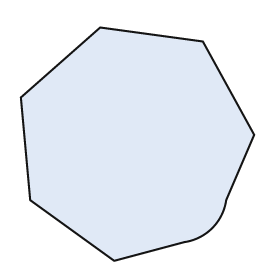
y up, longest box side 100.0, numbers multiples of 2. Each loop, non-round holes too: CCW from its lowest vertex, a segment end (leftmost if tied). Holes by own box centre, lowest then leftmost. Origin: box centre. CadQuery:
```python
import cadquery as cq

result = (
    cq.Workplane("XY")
    .moveTo(-10.0, -50.0)
    .lineTo(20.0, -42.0)
    .threePointArc((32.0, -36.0), (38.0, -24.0))
    .lineTo(50.0, 4.0)
    .lineTo(28.0, 44.0)
    .lineTo(-16.0, 50.0)
    .lineTo(-50.0, 20.0)
    .lineTo(-46.0, -24.0)
    .close()
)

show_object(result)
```